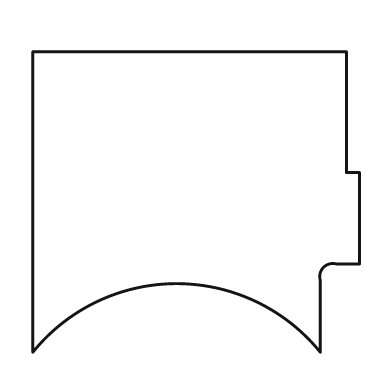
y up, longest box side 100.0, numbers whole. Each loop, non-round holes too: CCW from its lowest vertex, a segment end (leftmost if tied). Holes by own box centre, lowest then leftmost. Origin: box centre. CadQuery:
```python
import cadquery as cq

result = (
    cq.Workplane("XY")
    .moveTo(-50.0, -46.0)
    .threePointArc((-6.0, -25.0), (38.0, -46.0))
    .lineTo(38.0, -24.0)
    .threePointArc((39.0, -20.0), (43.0, -19.0))
    .lineTo(50.0, -19.0)
    .lineTo(50.0, 9.0)
    .lineTo(46.0, 9.0)
    .lineTo(46.0, 46.0)
    .lineTo(-50.0, 46.0)
    .close()
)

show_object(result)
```